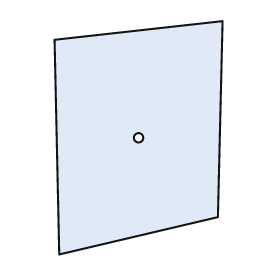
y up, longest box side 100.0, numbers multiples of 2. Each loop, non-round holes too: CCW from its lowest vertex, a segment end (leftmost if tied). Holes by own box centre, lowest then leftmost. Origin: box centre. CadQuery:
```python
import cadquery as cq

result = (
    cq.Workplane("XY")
    .moveTo(-34.0, -50.0)
    .lineTo(34.0, -34.0)
    .lineTo(36.0, 50.0)
    .lineTo(-36.0, 42.0)
    .close()
    .moveTo(0.0, 0.0)
    .circle(2.0)
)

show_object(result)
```